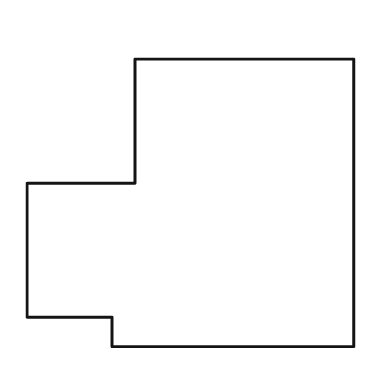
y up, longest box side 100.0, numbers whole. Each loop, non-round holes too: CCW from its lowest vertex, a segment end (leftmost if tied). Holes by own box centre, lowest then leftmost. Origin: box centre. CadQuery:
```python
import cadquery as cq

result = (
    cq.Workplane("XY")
    .moveTo(-24.0, -44.0)
    .lineTo(50.0, -44.0)
    .lineTo(50.0, 44.0)
    .lineTo(-17.0, 44.0)
    .lineTo(-17.0, 6.0)
    .lineTo(-50.0, 6.0)
    .lineTo(-50.0, -35.0)
    .lineTo(-24.0, -35.0)
    .close()
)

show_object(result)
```